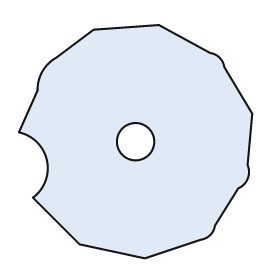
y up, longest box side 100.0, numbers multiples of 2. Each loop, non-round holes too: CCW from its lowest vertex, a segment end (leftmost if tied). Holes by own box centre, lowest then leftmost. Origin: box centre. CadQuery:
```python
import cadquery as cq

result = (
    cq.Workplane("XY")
    .moveTo(4.0, -50.0)
    .lineTo(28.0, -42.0)
    .threePointArc((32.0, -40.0), (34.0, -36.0))
    .lineTo(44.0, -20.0)
    .threePointArc((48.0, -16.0), (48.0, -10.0))
    .lineTo(50.0, 12.0)
    .lineTo(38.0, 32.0)
    .threePointArc((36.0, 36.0), (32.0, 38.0))
    .lineTo(10.0, 50.0)
    .lineTo(-18.0, 48.0)
    .lineTo(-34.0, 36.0)
    .threePointArc((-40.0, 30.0), (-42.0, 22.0))
    .lineTo(-50.0, 4.0)
    .threePointArc((-38.0, -8.0), (-44.0, -24.0))
    .lineTo(-24.0, -44.0)
    .close()
    .moveTo(0.0, 0.0)
    .circle(8.0)
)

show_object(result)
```